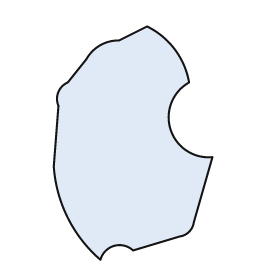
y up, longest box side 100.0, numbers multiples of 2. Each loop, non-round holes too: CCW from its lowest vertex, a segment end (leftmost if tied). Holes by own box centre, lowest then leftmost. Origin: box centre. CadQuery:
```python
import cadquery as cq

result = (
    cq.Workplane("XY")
    .moveTo(-14.0, -50.0)
    .threePointArc((-8.0, -44.0), (0.0, -46.0))
    .lineTo(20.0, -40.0)
    .threePointArc((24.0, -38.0), (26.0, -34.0))
    .lineTo(34.0, -6.0)
    .threePointArc((16.0, 6.0), (24.0, 26.0))
    .threePointArc((18.0, 40.0), (6.0, 50.0))
    .lineTo(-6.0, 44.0)
    .threePointArc((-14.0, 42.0), (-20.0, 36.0))
    .lineTo(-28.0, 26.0)
    .threePointArc((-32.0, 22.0), (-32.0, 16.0))
    .lineTo(-34.0, -10.0)
    .threePointArc((-28.0, -32.0), (-14.0, -50.0))
    .close()
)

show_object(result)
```